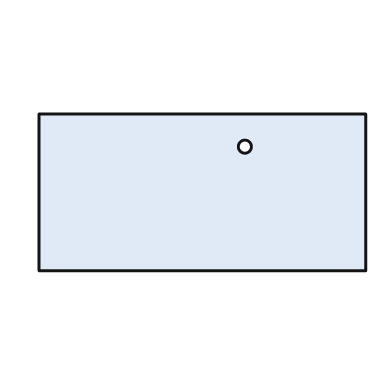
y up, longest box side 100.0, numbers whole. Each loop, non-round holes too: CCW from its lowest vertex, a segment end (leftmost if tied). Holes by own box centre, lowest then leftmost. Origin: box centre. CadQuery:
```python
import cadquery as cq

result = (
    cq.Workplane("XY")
    .moveTo(-50.0, -24.0)
    .lineTo(50.0, -24.0)
    .lineTo(50.0, 24.0)
    .lineTo(-50.0, 24.0)
    .close()
    .moveTo(13.0, 14.0)
    .circle(2.0)
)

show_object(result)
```